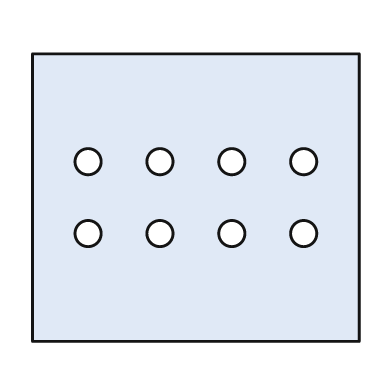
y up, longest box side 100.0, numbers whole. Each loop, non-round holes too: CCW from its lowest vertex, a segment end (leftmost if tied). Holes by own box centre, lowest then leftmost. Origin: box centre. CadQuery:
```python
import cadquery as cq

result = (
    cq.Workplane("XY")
    .moveTo(-50.0, -44.0)
    .lineTo(50.0, -44.0)
    .lineTo(50.0, 44.0)
    .lineTo(-50.0, 44.0)
    .close()
    .moveTo(-33.0, -11.0)
    .circle(4.0)
    .moveTo(-11.0, -11.0)
    .circle(4.0)
    .moveTo(11.0, -11.0)
    .circle(4.0)
    .moveTo(33.0, -11.0)
    .circle(4.0)
    .moveTo(-33.0, 11.0)
    .circle(4.0)
    .moveTo(-11.0, 11.0)
    .circle(4.0)
    .moveTo(11.0, 11.0)
    .circle(4.0)
    .moveTo(33.0, 11.0)
    .circle(4.0)
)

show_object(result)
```